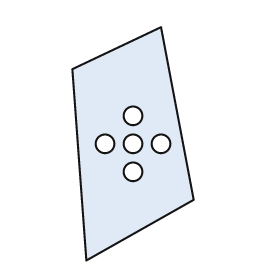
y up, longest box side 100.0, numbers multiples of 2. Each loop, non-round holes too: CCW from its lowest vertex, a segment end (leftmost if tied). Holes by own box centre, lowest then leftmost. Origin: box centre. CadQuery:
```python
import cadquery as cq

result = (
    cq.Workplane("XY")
    .moveTo(-20.0, -50.0)
    .lineTo(26.0, -24.0)
    .lineTo(12.0, 50.0)
    .lineTo(-26.0, 32.0)
    .close()
    .moveTo(0.0, -12.0)
    .circle(4.0)
    .moveTo(-12.0, 0.0)
    .circle(4.0)
    .moveTo(0.0, 0.0)
    .circle(4.0)
    .moveTo(12.0, 0.0)
    .circle(4.0)
    .moveTo(0.0, 12.0)
    .circle(4.0)
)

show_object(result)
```